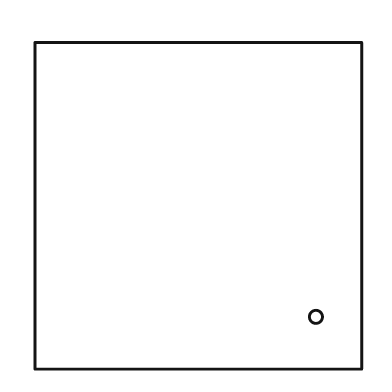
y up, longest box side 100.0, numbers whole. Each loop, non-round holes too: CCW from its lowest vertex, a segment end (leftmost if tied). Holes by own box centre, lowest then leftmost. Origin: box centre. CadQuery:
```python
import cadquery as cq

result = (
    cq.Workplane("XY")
    .moveTo(-50.0, -50.0)
    .lineTo(50.0, -50.0)
    .lineTo(50.0, 50.0)
    .lineTo(-50.0, 50.0)
    .close()
    .moveTo(36.0, -34.0)
    .circle(2.0)
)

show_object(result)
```